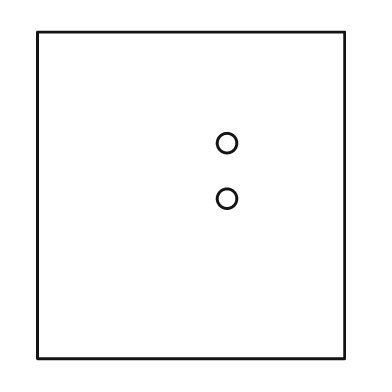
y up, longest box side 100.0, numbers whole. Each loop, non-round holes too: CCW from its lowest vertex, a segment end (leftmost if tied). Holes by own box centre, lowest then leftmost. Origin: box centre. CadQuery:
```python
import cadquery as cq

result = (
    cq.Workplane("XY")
    .moveTo(-47.0, -50.0)
    .lineTo(47.0, -50.0)
    .lineTo(47.0, 50.0)
    .lineTo(-47.0, 50.0)
    .close()
    .moveTo(11.0, -1.0)
    .circle(3.0)
    .moveTo(11.0, 16.0)
    .circle(3.0)
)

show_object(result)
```